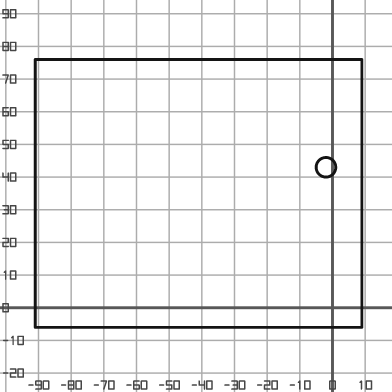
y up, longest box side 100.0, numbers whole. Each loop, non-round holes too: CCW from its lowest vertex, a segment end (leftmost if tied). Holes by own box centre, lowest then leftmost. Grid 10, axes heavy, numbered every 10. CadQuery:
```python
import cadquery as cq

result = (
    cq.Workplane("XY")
    .moveTo(-91.0, -6.0)
    .lineTo(9.0, -6.0)
    .lineTo(9.0, 76.0)
    .lineTo(-91.0, 76.0)
    .close()
    .moveTo(-2.0, 43.0)
    .circle(3.0)
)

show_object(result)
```